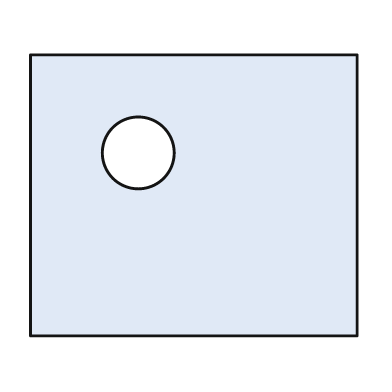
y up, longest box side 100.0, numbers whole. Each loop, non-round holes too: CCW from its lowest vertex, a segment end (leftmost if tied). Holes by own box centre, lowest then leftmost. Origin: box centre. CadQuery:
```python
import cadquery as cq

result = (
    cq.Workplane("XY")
    .moveTo(-50.0, -43.0)
    .lineTo(50.0, -43.0)
    .lineTo(50.0, 43.0)
    .lineTo(-50.0, 43.0)
    .close()
    .moveTo(-17.0, 13.0)
    .circle(11.0)
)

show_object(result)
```